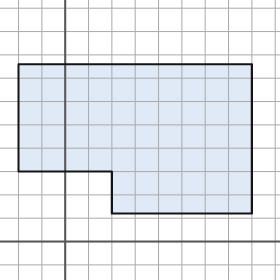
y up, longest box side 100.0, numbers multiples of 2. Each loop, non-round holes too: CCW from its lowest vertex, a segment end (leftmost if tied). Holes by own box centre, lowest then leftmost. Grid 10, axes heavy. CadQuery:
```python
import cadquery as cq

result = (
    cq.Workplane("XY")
    .moveTo(20.0, 12.0)
    .lineTo(80.0, 12.0)
    .lineTo(80.0, 76.0)
    .lineTo(-20.0, 76.0)
    .lineTo(-20.0, 30.0)
    .lineTo(20.0, 30.0)
    .close()
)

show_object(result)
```